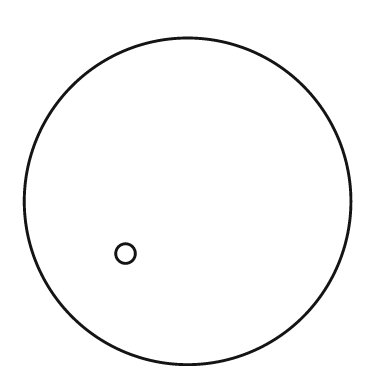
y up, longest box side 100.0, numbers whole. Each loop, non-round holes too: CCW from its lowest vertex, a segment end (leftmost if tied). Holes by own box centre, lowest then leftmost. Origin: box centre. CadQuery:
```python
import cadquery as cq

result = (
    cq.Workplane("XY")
    .moveTo(0.0, 0.0)
    .circle(50.0)
    .moveTo(-19.0, -16.0)
    .circle(3.0)
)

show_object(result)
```